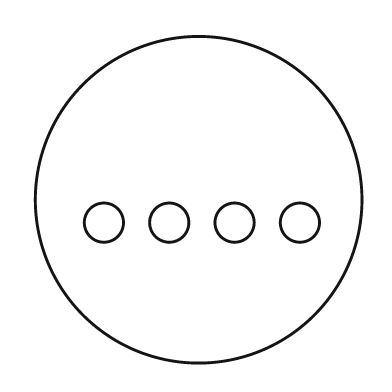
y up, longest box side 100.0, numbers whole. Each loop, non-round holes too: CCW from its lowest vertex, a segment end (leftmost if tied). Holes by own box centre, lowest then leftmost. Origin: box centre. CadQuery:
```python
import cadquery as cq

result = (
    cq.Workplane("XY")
    .moveTo(0.0, 0.0)
    .circle(50.0)
    .moveTo(-29.0, -7.0)
    .circle(6.0)
    .moveTo(-9.0, -7.0)
    .circle(6.0)
    .moveTo(11.0, -7.0)
    .circle(6.0)
    .moveTo(31.0, -7.0)
    .circle(6.0)
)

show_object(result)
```